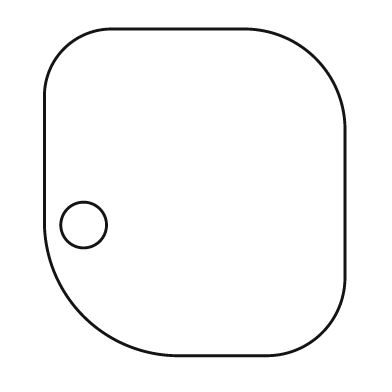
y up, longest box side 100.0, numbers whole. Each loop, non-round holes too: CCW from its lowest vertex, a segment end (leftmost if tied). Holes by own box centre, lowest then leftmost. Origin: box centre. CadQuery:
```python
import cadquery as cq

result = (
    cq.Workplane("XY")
    .moveTo(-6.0, -50.0)
    .lineTo(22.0, -50.0)
    .threePointArc((39.0, -43.0), (46.0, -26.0))
    .lineTo(46.0, 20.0)
    .threePointArc((37.0, 41.0), (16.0, 50.0))
    .lineTo(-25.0, 50.0)
    .threePointArc((-40.0, 44.0), (-46.0, 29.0))
    .lineTo(-46.0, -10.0)
    .threePointArc((-34.0, -38.0), (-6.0, -50.0))
    .close()
    .moveTo(-34.0, -10.0)
    .circle(7.0)
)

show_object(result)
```